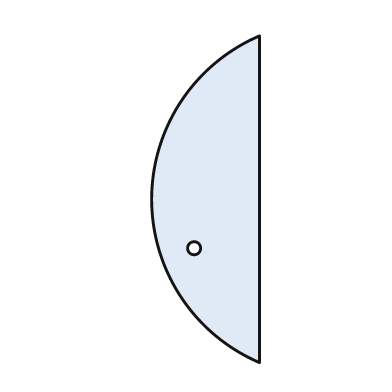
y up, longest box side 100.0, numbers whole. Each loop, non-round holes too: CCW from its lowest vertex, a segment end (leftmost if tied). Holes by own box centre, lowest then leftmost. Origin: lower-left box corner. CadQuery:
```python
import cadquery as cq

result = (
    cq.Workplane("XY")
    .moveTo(33.0, 0.0)
    .lineTo(33.0, 100.0)
    .threePointArc((0.0, 50.0), (33.0, 0.0))
    .close()
    .moveTo(13.0, 35.0)
    .circle(2.0)
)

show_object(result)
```